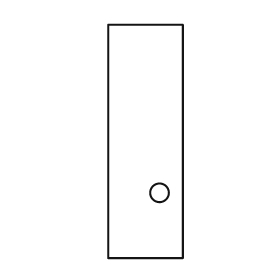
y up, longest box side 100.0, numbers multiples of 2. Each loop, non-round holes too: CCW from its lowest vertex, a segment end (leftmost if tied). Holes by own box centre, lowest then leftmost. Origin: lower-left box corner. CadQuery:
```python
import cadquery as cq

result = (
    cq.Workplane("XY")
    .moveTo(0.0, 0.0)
    .lineTo(32.0, 0.0)
    .lineTo(32.0, 100.0)
    .lineTo(0.0, 100.0)
    .close()
    .moveTo(22.0, 28.0)
    .circle(4.0)
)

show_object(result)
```